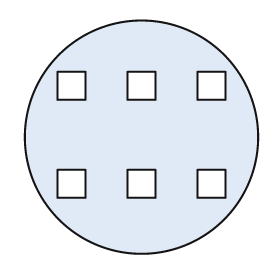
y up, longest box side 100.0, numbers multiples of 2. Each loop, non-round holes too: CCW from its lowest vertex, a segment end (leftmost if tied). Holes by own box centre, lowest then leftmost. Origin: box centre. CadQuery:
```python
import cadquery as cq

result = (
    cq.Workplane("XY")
    .moveTo(0.0, 0.0)
    .circle(50.0)
    .moveTo(-36.0, -26.0)
    .lineTo(-24.0, -26.0)
    .lineTo(-24.0, -14.0)
    .lineTo(-36.0, -14.0)
    .close()
    .moveTo(-6.0, -26.0)
    .lineTo(6.0, -26.0)
    .lineTo(6.0, -14.0)
    .lineTo(-6.0, -14.0)
    .close()
    .moveTo(24.0, -26.0)
    .lineTo(36.0, -26.0)
    .lineTo(36.0, -14.0)
    .lineTo(24.0, -14.0)
    .close()
    .moveTo(-36.0, 16.0)
    .lineTo(-24.0, 16.0)
    .lineTo(-24.0, 28.0)
    .lineTo(-36.0, 28.0)
    .close()
    .moveTo(-6.0, 16.0)
    .lineTo(6.0, 16.0)
    .lineTo(6.0, 28.0)
    .lineTo(-6.0, 28.0)
    .close()
    .moveTo(24.0, 16.0)
    .lineTo(36.0, 16.0)
    .lineTo(36.0, 28.0)
    .lineTo(24.0, 28.0)
    .close()
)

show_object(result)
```